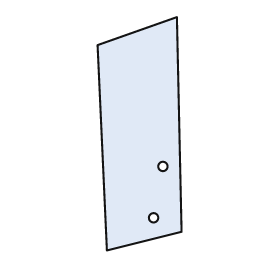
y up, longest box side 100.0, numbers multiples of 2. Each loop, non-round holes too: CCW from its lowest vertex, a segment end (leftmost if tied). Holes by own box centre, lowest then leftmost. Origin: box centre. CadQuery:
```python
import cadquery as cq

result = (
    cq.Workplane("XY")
    .moveTo(-14.0, -50.0)
    .lineTo(18.0, -42.0)
    .lineTo(16.0, 50.0)
    .lineTo(-18.0, 38.0)
    .close()
    .moveTo(6.0, -36.0)
    .circle(2.0)
    .moveTo(10.0, -14.0)
    .circle(2.0)
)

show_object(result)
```